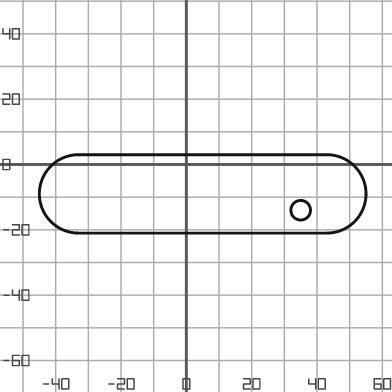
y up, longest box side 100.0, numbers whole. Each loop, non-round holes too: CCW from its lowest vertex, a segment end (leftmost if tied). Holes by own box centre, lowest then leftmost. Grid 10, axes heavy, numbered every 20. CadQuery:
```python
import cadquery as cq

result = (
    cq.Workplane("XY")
    .moveTo(-33.0, -21.0)
    .lineTo(43.0, -21.0)
    .threePointArc((55.0, -9.0), (43.0, 3.0))
    .lineTo(-33.0, 3.0)
    .threePointArc((-45.0, -9.0), (-33.0, -21.0))
    .close()
    .moveTo(35.0, -14.0)
    .circle(3.0)
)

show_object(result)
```